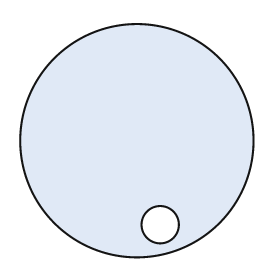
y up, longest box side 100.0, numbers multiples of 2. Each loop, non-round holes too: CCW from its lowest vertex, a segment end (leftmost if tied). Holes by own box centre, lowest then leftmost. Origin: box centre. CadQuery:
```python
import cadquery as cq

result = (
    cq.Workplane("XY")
    .moveTo(0.0, 0.0)
    .circle(50.0)
    .moveTo(10.0, -36.0)
    .circle(8.0)
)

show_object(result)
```